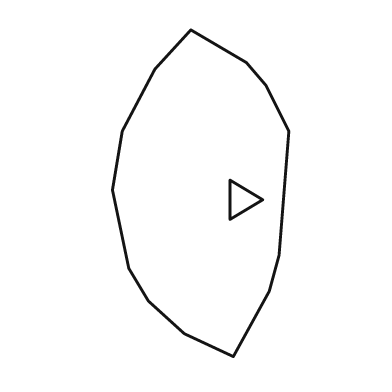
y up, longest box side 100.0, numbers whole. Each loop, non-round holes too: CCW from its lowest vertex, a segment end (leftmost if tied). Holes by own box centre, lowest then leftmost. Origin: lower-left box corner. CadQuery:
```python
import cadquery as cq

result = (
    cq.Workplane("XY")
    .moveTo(37.0, 0.0)
    .lineTo(48.0, 20.0)
    .lineTo(51.0, 31.0)
    .lineTo(54.0, 69.0)
    .lineTo(47.0, 83.0)
    .lineTo(41.0, 90.0)
    .lineTo(24.0, 100.0)
    .lineTo(13.0, 88.0)
    .lineTo(3.0, 69.0)
    .lineTo(0.0, 51.0)
    .lineTo(5.0, 27.0)
    .lineTo(11.0, 17.0)
    .lineTo(22.0, 7.0)
    .close()
    .moveTo(36.0, 42.0)
    .lineTo(46.0, 48.0)
    .lineTo(36.0, 54.0)
    .close()
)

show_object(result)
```